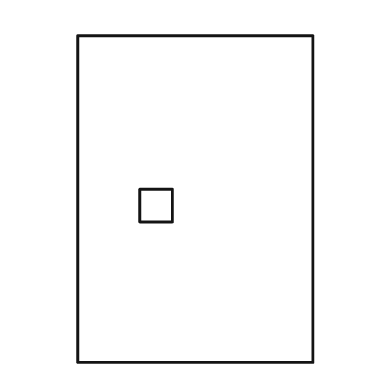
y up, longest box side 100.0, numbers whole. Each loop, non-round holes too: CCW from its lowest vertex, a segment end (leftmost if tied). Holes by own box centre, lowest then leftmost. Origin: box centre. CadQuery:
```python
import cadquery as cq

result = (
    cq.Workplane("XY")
    .moveTo(-36.0, -50.0)
    .lineTo(36.0, -50.0)
    .lineTo(36.0, 50.0)
    .lineTo(-36.0, 50.0)
    .close()
    .moveTo(-17.0, -7.0)
    .lineTo(-7.0, -7.0)
    .lineTo(-7.0, 3.0)
    .lineTo(-17.0, 3.0)
    .close()
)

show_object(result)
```